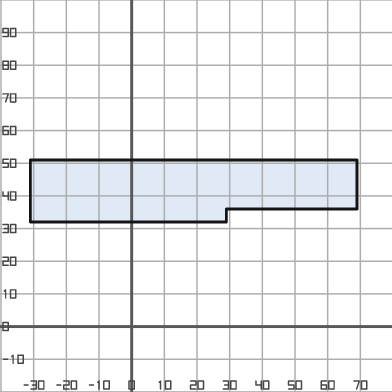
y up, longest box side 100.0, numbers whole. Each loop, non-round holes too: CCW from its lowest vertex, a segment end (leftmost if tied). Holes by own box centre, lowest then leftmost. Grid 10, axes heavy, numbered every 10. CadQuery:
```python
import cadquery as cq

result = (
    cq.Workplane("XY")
    .moveTo(-31.0, 32.0)
    .lineTo(29.0, 32.0)
    .lineTo(29.0, 36.0)
    .lineTo(69.0, 36.0)
    .lineTo(69.0, 51.0)
    .lineTo(-31.0, 51.0)
    .close()
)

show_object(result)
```